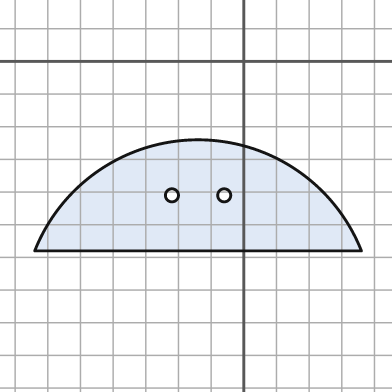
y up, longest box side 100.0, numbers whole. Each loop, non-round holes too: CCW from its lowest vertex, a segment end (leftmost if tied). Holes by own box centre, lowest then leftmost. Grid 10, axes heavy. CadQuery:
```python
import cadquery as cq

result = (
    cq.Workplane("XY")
    .moveTo(-64.0, -58.0)
    .lineTo(36.0, -58.0)
    .threePointArc((-14.0, -24.0), (-64.0, -58.0))
    .close()
    .moveTo(-22.0, -41.0)
    .circle(2.0)
    .moveTo(-6.0, -41.0)
    .circle(2.0)
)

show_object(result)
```